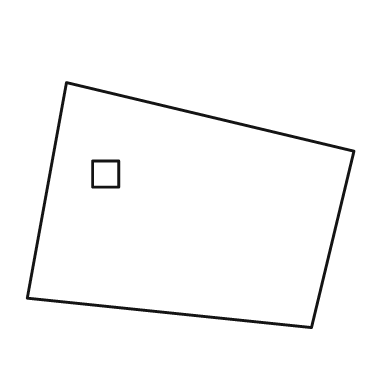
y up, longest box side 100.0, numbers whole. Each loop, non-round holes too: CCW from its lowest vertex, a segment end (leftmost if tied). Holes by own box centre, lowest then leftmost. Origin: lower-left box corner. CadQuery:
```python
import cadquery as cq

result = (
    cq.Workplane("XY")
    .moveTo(87.0, 0.0)
    .lineTo(100.0, 54.0)
    .lineTo(12.0, 75.0)
    .lineTo(0.0, 9.0)
    .close()
    .moveTo(20.0, 43.0)
    .lineTo(28.0, 43.0)
    .lineTo(28.0, 51.0)
    .lineTo(20.0, 51.0)
    .close()
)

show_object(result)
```